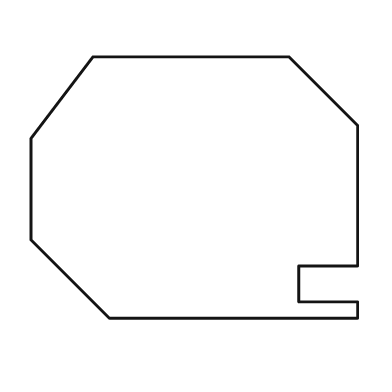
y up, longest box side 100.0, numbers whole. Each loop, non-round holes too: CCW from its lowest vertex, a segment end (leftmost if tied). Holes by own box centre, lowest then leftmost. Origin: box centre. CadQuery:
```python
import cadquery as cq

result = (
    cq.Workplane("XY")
    .moveTo(-26.0, -40.0)
    .lineTo(50.0, -40.0)
    .lineTo(50.0, -35.0)
    .lineTo(32.0, -35.0)
    .lineTo(32.0, -24.0)
    .lineTo(50.0, -24.0)
    .lineTo(50.0, 19.0)
    .lineTo(29.0, 40.0)
    .lineTo(-31.0, 40.0)
    .lineTo(-50.0, 15.0)
    .lineTo(-50.0, -16.0)
    .close()
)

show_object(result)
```